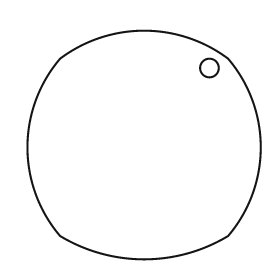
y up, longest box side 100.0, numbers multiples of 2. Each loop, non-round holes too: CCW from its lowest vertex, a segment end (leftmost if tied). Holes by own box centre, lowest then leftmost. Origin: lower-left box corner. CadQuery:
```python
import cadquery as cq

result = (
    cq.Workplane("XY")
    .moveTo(14.0, 10.0)
    .threePointArc((50.0, 0.0), (86.0, 10.0))
    .threePointArc((100.0, 48.0), (86.0, 86.0))
    .threePointArc((50.0, 98.0), (14.0, 86.0))
    .threePointArc((0.0, 48.0), (14.0, 10.0))
    .close()
    .moveTo(78.0, 82.0)
    .circle(4.0)
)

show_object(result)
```